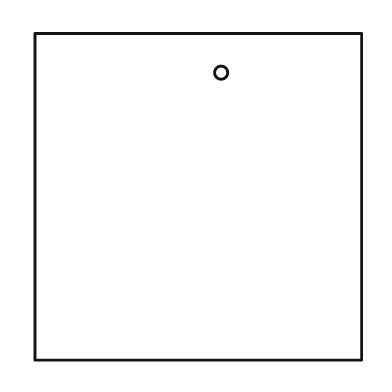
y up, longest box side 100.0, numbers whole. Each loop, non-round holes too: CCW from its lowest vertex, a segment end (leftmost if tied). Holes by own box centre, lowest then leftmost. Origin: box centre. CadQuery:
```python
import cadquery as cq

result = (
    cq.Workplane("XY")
    .moveTo(-50.0, -50.0)
    .lineTo(50.0, -50.0)
    .lineTo(50.0, 50.0)
    .lineTo(-50.0, 50.0)
    .close()
    .moveTo(7.0, 38.0)
    .circle(2.0)
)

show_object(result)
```